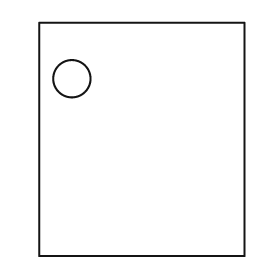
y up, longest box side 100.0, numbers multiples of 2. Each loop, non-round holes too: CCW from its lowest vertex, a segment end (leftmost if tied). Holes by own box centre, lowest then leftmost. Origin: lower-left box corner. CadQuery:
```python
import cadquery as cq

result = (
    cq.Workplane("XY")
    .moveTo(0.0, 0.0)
    .lineTo(88.0, 0.0)
    .lineTo(88.0, 100.0)
    .lineTo(0.0, 100.0)
    .close()
    .moveTo(14.0, 76.0)
    .circle(8.0)
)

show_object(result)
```